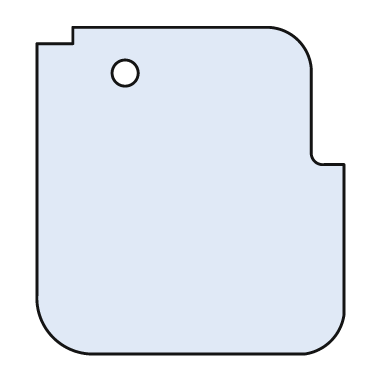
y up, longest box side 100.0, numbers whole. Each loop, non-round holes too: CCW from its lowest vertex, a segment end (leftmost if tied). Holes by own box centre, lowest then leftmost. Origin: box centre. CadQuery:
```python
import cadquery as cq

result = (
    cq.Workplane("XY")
    .moveTo(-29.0, -50.0)
    .lineTo(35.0, -50.0)
    .threePointArc((43.0, -46.0), (47.0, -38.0))
    .lineTo(47.0, 8.0)
    .lineTo(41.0, 8.0)
    .threePointArc((38.0, 9.0), (37.0, 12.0))
    .lineTo(37.0, 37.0)
    .threePointArc((33.0, 46.0), (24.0, 50.0))
    .lineTo(-36.0, 50.0)
    .lineTo(-36.0, 45.0)
    .lineTo(-47.0, 45.0)
    .lineTo(-47.0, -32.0)
    .threePointArc((-42.0, -45.0), (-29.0, -50.0))
    .close()
    .moveTo(-20.0, 36.0)
    .circle(4.0)
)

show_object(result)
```